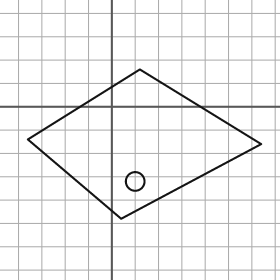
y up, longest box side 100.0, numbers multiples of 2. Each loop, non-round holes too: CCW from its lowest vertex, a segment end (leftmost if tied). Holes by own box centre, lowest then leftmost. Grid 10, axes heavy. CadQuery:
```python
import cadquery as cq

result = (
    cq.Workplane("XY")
    .moveTo(4.0, -48.0)
    .lineTo(64.0, -16.0)
    .lineTo(12.0, 16.0)
    .lineTo(-36.0, -14.0)
    .close()
    .moveTo(10.0, -32.0)
    .circle(4.0)
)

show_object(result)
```